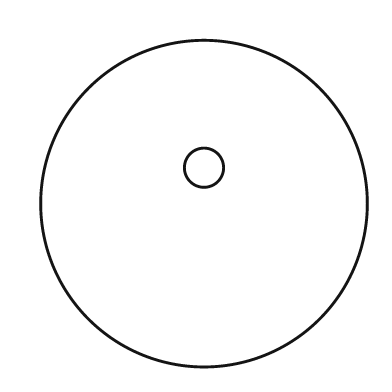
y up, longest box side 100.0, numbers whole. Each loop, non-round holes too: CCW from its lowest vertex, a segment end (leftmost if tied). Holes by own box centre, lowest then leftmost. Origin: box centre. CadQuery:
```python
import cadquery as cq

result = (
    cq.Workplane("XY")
    .moveTo(0.0, 0.0)
    .circle(50.0)
    .moveTo(0.0, 11.0)
    .circle(6.0)
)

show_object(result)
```